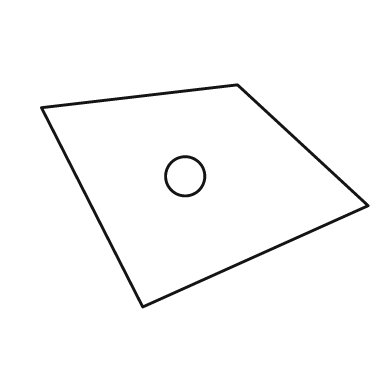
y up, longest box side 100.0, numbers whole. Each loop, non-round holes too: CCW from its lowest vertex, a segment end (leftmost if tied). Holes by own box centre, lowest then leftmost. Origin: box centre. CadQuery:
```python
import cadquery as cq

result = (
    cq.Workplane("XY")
    .moveTo(-19.0, -34.0)
    .lineTo(50.0, -3.0)
    .lineTo(10.0, 34.0)
    .lineTo(-50.0, 27.0)
    .close()
    .moveTo(-6.0, 6.0)
    .circle(6.0)
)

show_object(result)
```